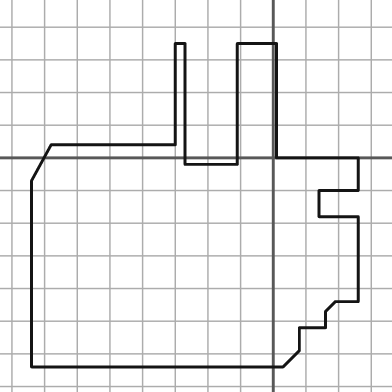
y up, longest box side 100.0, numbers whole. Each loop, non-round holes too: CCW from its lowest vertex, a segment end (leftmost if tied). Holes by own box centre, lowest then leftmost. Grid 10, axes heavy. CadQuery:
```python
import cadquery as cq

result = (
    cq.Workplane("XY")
    .moveTo(-74.0, -64.0)
    .lineTo(3.0, -64.0)
    .lineTo(8.0, -59.0)
    .lineTo(8.0, -52.0)
    .lineTo(16.0, -52.0)
    .lineTo(16.0, -47.0)
    .lineTo(19.0, -44.0)
    .lineTo(26.0, -44.0)
    .lineTo(26.0, -18.0)
    .lineTo(14.0, -18.0)
    .lineTo(14.0, -10.0)
    .lineTo(26.0, -10.0)
    .lineTo(26.0, 0.0)
    .lineTo(1.0, 0.0)
    .lineTo(1.0, 35.0)
    .lineTo(-11.0, 35.0)
    .lineTo(-11.0, -2.0)
    .lineTo(-27.0, -2.0)
    .lineTo(-27.0, 35.0)
    .lineTo(-30.0, 35.0)
    .lineTo(-30.0, 4.0)
    .lineTo(-68.0, 4.0)
    .lineTo(-74.0, -7.0)
    .close()
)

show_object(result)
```